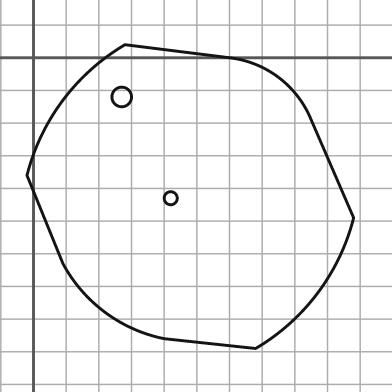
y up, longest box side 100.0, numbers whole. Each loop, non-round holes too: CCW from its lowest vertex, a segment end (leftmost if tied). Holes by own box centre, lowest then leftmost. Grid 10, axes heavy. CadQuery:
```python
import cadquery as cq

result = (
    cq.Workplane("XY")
    .moveTo(68.0, -89.0)
    .threePointArc((87.0, -72.0), (98.0, -49.0))
    .lineTo(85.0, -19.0)
    .threePointArc((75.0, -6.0), (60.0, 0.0))
    .lineTo(28.0, 4.0)
    .threePointArc((9.0, -13.0), (-2.0, -36.0))
    .lineTo(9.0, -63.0)
    .threePointArc((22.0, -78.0), (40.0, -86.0))
    .close()
    .moveTo(42.0, -43.0)
    .circle(2.0)
    .moveTo(27.0, -12.0)
    .circle(3.0)
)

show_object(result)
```